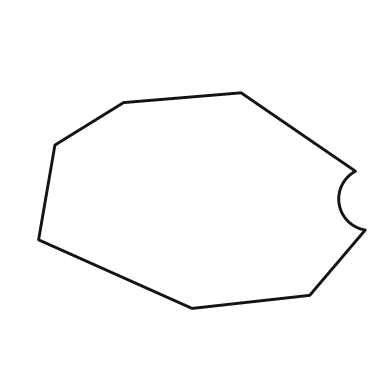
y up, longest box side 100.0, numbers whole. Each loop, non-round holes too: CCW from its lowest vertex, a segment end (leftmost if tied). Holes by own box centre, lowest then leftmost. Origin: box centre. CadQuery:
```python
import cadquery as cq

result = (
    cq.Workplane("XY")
    .moveTo(-3.0, -33.0)
    .lineTo(33.0, -29.0)
    .lineTo(50.0, -9.0)
    .threePointArc((42.0, -1.0), (47.0, 9.0))
    .lineTo(12.0, 33.0)
    .lineTo(-24.0, 30.0)
    .lineTo(-45.0, 17.0)
    .lineTo(-50.0, -12.0)
    .close()
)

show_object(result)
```